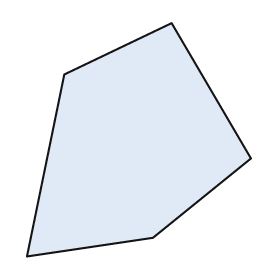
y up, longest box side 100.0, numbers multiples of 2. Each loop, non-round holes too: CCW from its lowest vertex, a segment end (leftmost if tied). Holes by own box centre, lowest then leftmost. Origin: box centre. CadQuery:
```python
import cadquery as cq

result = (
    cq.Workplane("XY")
    .moveTo(-48.0, -50.0)
    .lineTo(6.0, -42.0)
    .lineTo(48.0, -8.0)
    .lineTo(14.0, 50.0)
    .lineTo(-32.0, 28.0)
    .close()
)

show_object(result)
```